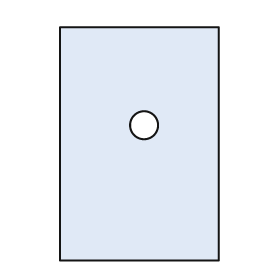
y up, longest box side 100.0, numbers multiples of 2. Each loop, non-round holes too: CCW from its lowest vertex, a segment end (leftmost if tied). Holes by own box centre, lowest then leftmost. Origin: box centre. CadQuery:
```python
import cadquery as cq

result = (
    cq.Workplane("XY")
    .moveTo(-34.0, -50.0)
    .lineTo(34.0, -50.0)
    .lineTo(34.0, 50.0)
    .lineTo(-34.0, 50.0)
    .close()
    .moveTo(2.0, 8.0)
    .circle(6.0)
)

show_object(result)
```